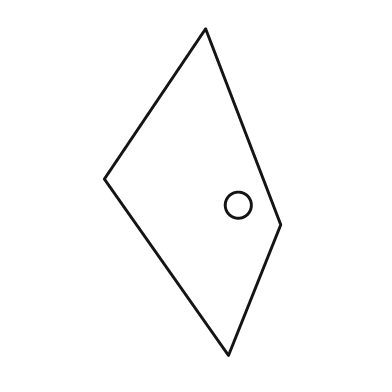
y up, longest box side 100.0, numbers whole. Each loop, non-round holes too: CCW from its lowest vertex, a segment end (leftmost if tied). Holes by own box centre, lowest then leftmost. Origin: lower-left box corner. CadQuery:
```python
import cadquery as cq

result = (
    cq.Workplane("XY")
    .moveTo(38.0, 0.0)
    .lineTo(54.0, 40.0)
    .lineTo(31.0, 100.0)
    .lineTo(0.0, 54.0)
    .close()
    .moveTo(41.0, 46.0)
    .circle(4.0)
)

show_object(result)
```